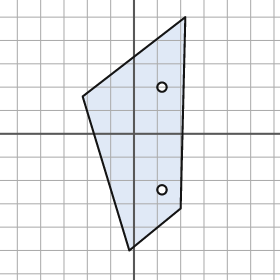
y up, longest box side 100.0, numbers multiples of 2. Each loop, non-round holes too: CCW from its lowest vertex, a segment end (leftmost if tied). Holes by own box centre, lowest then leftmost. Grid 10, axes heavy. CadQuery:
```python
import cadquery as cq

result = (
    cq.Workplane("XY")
    .moveTo(-2.0, -50.0)
    .lineTo(20.0, -32.0)
    .lineTo(22.0, 50.0)
    .lineTo(-22.0, 16.0)
    .close()
    .moveTo(12.0, -24.0)
    .circle(2.0)
    .moveTo(12.0, 20.0)
    .circle(2.0)
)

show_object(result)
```